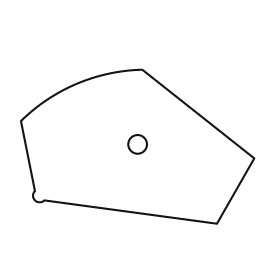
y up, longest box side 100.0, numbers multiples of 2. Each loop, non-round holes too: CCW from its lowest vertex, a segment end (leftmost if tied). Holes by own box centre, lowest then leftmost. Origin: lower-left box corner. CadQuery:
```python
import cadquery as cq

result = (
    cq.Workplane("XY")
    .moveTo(84.0, 0.0)
    .lineTo(100.0, 28.0)
    .lineTo(52.0, 66.0)
    .threePointArc((24.0, 60.0), (0.0, 44.0))
    .lineTo(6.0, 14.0)
    .threePointArc((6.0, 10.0), (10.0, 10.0))
    .close()
    .moveTo(50.0, 34.0)
    .circle(4.0)
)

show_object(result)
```